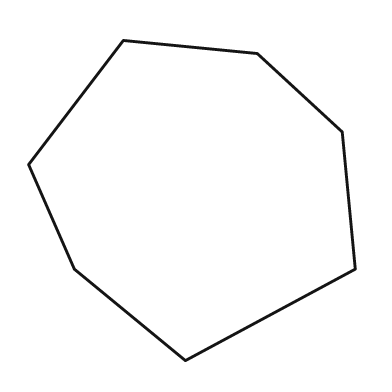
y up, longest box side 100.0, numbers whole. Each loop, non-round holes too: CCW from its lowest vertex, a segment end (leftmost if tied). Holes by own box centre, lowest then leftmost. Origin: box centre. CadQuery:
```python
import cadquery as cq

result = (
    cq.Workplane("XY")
    .moveTo(-2.0, -49.0)
    .lineTo(50.0, -21.0)
    .lineTo(46.0, 21.0)
    .lineTo(20.0, 45.0)
    .lineTo(-21.0, 49.0)
    .lineTo(-50.0, 11.0)
    .lineTo(-36.0, -21.0)
    .close()
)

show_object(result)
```